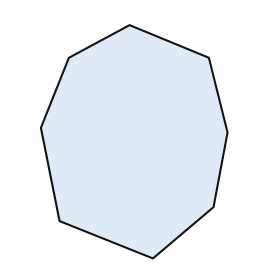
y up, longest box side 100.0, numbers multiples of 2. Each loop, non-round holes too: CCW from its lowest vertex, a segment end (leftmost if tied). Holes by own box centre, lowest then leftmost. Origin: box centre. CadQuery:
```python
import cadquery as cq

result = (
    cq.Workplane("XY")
    .moveTo(8.0, -50.0)
    .lineTo(34.0, -28.0)
    .lineTo(40.0, 4.0)
    .lineTo(32.0, 36.0)
    .lineTo(-2.0, 50.0)
    .lineTo(-28.0, 36.0)
    .lineTo(-40.0, 6.0)
    .lineTo(-32.0, -34.0)
    .close()
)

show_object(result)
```